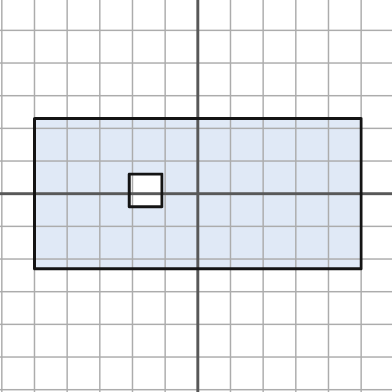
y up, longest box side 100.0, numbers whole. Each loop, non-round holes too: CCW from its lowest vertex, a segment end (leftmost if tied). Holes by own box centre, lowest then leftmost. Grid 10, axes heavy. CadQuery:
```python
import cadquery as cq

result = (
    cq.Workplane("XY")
    .moveTo(-50.0, -23.0)
    .lineTo(50.0, -23.0)
    .lineTo(50.0, 23.0)
    .lineTo(-50.0, 23.0)
    .close()
    .moveTo(-21.0, -4.0)
    .lineTo(-11.0, -4.0)
    .lineTo(-11.0, 6.0)
    .lineTo(-21.0, 6.0)
    .close()
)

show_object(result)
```